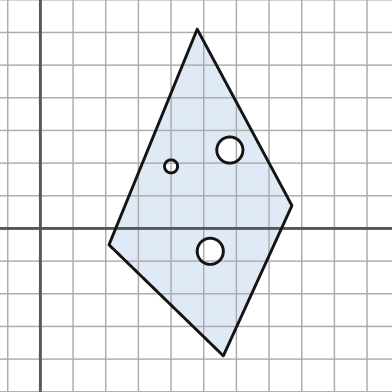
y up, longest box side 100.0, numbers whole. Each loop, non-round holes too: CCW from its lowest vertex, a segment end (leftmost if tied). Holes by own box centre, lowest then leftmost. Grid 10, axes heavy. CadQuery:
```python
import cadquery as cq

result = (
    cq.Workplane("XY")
    .moveTo(56.0, -39.0)
    .lineTo(77.0, 7.0)
    .lineTo(48.0, 61.0)
    .lineTo(21.0, -5.0)
    .close()
    .moveTo(52.0, -7.0)
    .circle(4.0)
    .moveTo(40.0, 19.0)
    .circle(2.0)
    .moveTo(58.0, 24.0)
    .circle(4.0)
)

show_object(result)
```